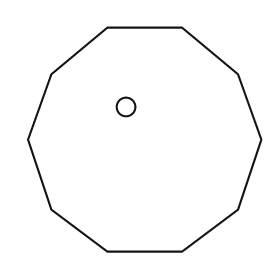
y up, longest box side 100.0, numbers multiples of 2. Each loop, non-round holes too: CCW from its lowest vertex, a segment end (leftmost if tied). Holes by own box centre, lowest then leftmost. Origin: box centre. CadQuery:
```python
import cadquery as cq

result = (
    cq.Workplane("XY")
    .moveTo(-16.0, -48.0)
    .lineTo(16.0, -48.0)
    .lineTo(40.0, -30.0)
    .lineTo(50.0, 0.0)
    .lineTo(40.0, 28.0)
    .lineTo(16.0, 48.0)
    .lineTo(-16.0, 48.0)
    .lineTo(-40.0, 28.0)
    .lineTo(-50.0, 0.0)
    .lineTo(-40.0, -30.0)
    .close()
    .moveTo(-8.0, 14.0)
    .circle(4.0)
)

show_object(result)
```